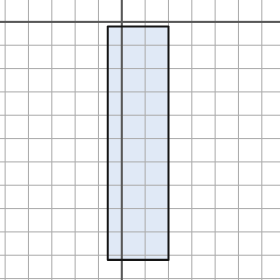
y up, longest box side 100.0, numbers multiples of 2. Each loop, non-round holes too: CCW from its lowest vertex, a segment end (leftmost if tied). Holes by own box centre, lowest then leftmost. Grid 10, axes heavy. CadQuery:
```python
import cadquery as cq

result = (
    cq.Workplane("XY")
    .moveTo(-6.0, -102.0)
    .lineTo(20.0, -102.0)
    .lineTo(20.0, -2.0)
    .lineTo(-6.0, -2.0)
    .close()
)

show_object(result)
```